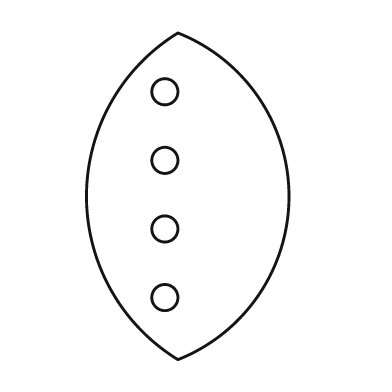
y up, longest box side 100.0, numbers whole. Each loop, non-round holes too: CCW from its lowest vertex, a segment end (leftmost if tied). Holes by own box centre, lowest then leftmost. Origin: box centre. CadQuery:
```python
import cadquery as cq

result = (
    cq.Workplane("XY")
    .moveTo(-3.0, -50.0)
    .threePointArc((31.0, 0.0), (-3.0, 50.0))
    .threePointArc((-31.0, 0.0), (-3.0, -50.0))
    .close()
    .moveTo(-7.0, -31.0)
    .circle(4.0)
    .moveTo(-7.0, -10.0)
    .circle(4.0)
    .moveTo(-7.0, 11.0)
    .circle(4.0)
    .moveTo(-7.0, 32.0)
    .circle(4.0)
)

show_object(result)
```